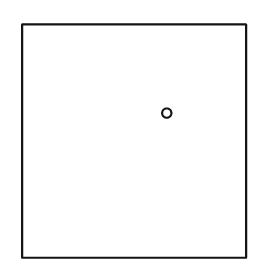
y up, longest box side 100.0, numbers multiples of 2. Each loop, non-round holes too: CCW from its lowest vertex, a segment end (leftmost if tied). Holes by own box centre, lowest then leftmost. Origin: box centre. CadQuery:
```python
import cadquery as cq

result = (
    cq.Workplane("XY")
    .moveTo(-48.0, -50.0)
    .lineTo(48.0, -50.0)
    .lineTo(48.0, 50.0)
    .lineTo(-48.0, 50.0)
    .close()
    .moveTo(14.0, 12.0)
    .circle(2.0)
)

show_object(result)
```